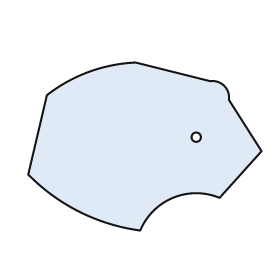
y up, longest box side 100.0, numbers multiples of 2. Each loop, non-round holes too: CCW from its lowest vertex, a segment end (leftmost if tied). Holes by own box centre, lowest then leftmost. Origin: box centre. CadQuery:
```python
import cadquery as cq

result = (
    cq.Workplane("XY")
    .moveTo(-2.0, -36.0)
    .threePointArc((12.0, -22.0), (32.0, -22.0))
    .lineTo(50.0, -2.0)
    .lineTo(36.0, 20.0)
    .threePointArc((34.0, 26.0), (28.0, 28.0))
    .lineTo(-4.0, 36.0)
    .threePointArc((-24.0, 32.0), (-42.0, 22.0))
    .lineTo(-50.0, -12.0)
    .threePointArc((-28.0, -28.0), (-2.0, -36.0))
    .close()
    .moveTo(22.0, 4.0)
    .circle(2.0)
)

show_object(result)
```